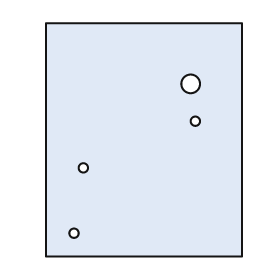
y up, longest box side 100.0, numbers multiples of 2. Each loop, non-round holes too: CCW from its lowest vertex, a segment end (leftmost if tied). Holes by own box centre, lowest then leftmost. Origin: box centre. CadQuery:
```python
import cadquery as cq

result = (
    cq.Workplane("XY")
    .moveTo(-42.0, -50.0)
    .lineTo(42.0, -50.0)
    .lineTo(42.0, 50.0)
    .lineTo(-42.0, 50.0)
    .close()
    .moveTo(-30.0, -40.0)
    .circle(2.0)
    .moveTo(-26.0, -12.0)
    .circle(2.0)
    .moveTo(22.0, 8.0)
    .circle(2.0)
    .moveTo(20.0, 24.0)
    .circle(4.0)
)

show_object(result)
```